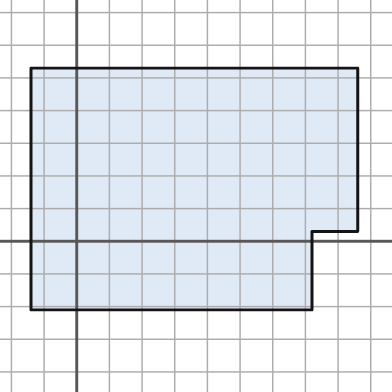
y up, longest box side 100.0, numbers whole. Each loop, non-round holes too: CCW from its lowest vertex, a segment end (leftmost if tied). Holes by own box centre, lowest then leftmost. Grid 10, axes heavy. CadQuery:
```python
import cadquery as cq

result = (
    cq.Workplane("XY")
    .moveTo(-14.0, -21.0)
    .lineTo(72.0, -21.0)
    .lineTo(72.0, 3.0)
    .lineTo(86.0, 3.0)
    .lineTo(86.0, 53.0)
    .lineTo(-14.0, 53.0)
    .close()
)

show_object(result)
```